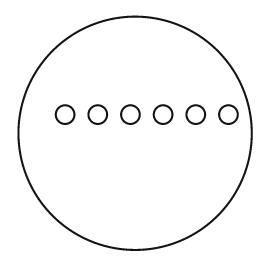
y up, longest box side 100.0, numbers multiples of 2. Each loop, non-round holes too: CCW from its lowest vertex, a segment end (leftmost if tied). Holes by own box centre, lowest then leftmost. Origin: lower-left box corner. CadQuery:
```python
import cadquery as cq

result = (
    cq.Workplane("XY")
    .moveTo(50.0, 50.0)
    .circle(50.0)
    .moveTo(20.0, 58.0)
    .circle(4.0)
    .moveTo(34.0, 58.0)
    .circle(4.0)
    .moveTo(48.0, 58.0)
    .circle(4.0)
    .moveTo(62.0, 58.0)
    .circle(4.0)
    .moveTo(76.0, 58.0)
    .circle(4.0)
    .moveTo(90.0, 58.0)
    .circle(4.0)
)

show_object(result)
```